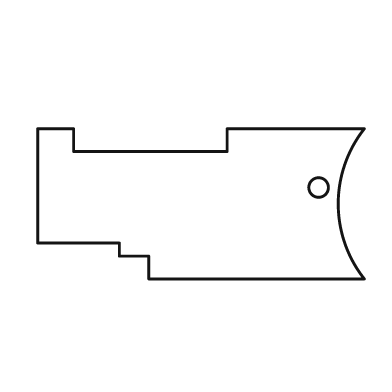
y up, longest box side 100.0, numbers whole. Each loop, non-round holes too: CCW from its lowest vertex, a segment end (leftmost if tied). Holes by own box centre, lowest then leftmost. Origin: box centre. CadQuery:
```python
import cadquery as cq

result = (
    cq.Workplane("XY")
    .moveTo(-16.0, -23.0)
    .lineTo(50.0, -23.0)
    .threePointArc((42.0, 0.0), (50.0, 23.0))
    .lineTo(8.0, 23.0)
    .lineTo(8.0, 16.0)
    .lineTo(-39.0, 16.0)
    .lineTo(-39.0, 23.0)
    .lineTo(-50.0, 23.0)
    .lineTo(-50.0, -12.0)
    .lineTo(-25.0, -12.0)
    .lineTo(-25.0, -16.0)
    .lineTo(-16.0, -16.0)
    .close()
    .moveTo(36.0, 5.0)
    .circle(3.0)
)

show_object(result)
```